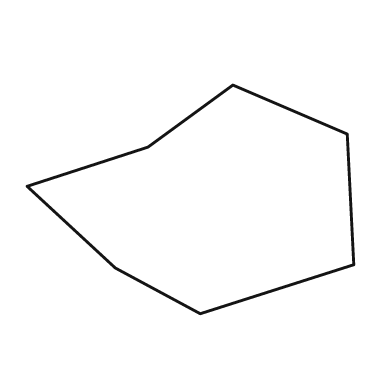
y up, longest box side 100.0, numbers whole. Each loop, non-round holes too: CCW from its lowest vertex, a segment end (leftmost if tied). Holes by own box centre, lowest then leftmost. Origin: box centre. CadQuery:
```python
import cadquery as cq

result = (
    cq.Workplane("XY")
    .moveTo(3.0, -35.0)
    .lineTo(50.0, -20.0)
    .lineTo(48.0, 20.0)
    .lineTo(13.0, 35.0)
    .lineTo(-13.0, 16.0)
    .lineTo(-50.0, 4.0)
    .lineTo(-23.0, -21.0)
    .close()
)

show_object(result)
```